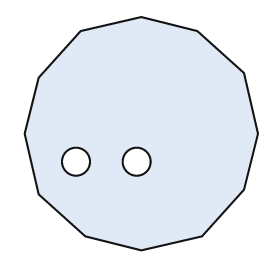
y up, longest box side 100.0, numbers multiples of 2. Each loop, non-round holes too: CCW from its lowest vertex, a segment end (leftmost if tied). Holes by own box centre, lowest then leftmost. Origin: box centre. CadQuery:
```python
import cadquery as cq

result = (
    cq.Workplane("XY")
    .moveTo(0.0, -50.0)
    .lineTo(26.0, -44.0)
    .lineTo(44.0, -24.0)
    .lineTo(50.0, 0.0)
    .lineTo(44.0, 26.0)
    .lineTo(24.0, 44.0)
    .lineTo(0.0, 50.0)
    .lineTo(-26.0, 44.0)
    .lineTo(-44.0, 24.0)
    .lineTo(-50.0, 0.0)
    .lineTo(-44.0, -26.0)
    .lineTo(-24.0, -44.0)
    .close()
    .moveTo(-28.0, -12.0)
    .circle(6.0)
    .moveTo(-2.0, -12.0)
    .circle(6.0)
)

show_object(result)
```